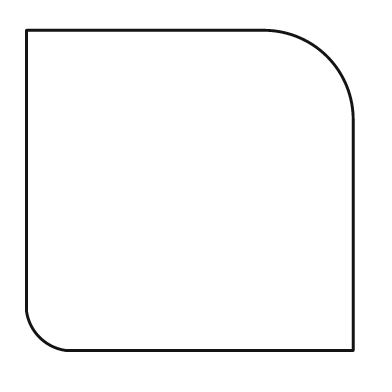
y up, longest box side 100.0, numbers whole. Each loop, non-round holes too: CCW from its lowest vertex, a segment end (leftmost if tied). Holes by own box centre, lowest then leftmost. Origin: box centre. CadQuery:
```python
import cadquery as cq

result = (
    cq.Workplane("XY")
    .moveTo(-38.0, -49.0)
    .lineTo(50.0, -49.0)
    .lineTo(50.0, 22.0)
    .threePointArc((42.0, 41.0), (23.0, 49.0))
    .lineTo(-50.0, 49.0)
    .lineTo(-50.0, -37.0)
    .threePointArc((-46.0, -45.0), (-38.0, -49.0))
    .close()
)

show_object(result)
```